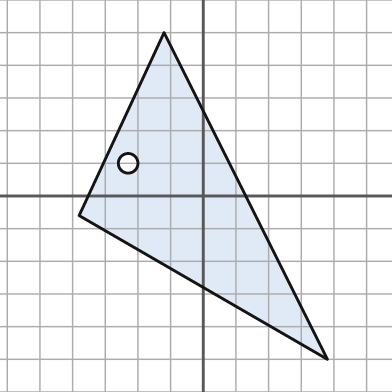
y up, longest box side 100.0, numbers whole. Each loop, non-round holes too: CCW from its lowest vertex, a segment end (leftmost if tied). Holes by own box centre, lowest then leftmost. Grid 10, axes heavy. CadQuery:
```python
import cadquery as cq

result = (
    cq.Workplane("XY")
    .moveTo(38.0, -50.0)
    .lineTo(-12.0, 50.0)
    .lineTo(-38.0, -6.0)
    .close()
    .moveTo(-23.0, 10.0)
    .circle(3.0)
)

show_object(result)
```